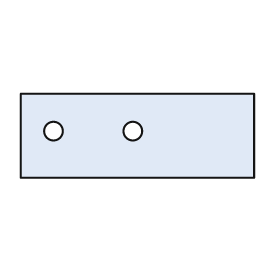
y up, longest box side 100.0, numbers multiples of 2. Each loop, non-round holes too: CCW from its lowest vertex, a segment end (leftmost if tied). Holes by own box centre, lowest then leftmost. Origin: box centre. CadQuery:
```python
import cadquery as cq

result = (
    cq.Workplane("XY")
    .moveTo(-50.0, -18.0)
    .lineTo(50.0, -18.0)
    .lineTo(50.0, 18.0)
    .lineTo(-50.0, 18.0)
    .close()
    .moveTo(-36.0, 2.0)
    .circle(4.0)
    .moveTo(-2.0, 2.0)
    .circle(4.0)
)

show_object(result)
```